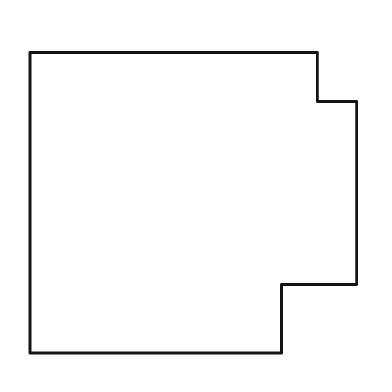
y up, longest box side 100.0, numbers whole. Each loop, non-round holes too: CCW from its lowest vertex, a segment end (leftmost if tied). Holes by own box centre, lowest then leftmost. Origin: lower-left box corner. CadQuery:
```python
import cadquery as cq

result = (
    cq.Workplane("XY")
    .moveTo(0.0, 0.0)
    .lineTo(77.0, 0.0)
    .lineTo(77.0, 21.0)
    .lineTo(100.0, 21.0)
    .lineTo(100.0, 77.0)
    .lineTo(88.0, 77.0)
    .lineTo(88.0, 92.0)
    .lineTo(0.0, 92.0)
    .close()
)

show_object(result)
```